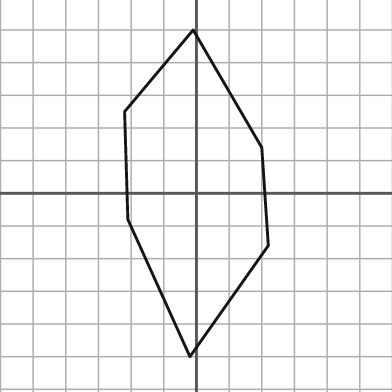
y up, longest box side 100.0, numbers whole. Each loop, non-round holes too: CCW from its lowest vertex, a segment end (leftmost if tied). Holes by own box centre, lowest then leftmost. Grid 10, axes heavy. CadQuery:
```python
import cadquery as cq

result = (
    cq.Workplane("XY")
    .moveTo(-2.0, -50.0)
    .lineTo(22.0, -16.0)
    .lineTo(20.0, 14.0)
    .lineTo(-1.0, 50.0)
    .lineTo(-22.0, 25.0)
    .lineTo(-21.0, -8.0)
    .close()
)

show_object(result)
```